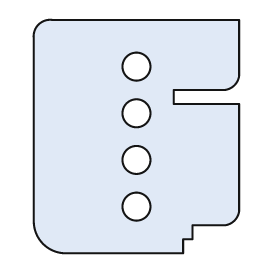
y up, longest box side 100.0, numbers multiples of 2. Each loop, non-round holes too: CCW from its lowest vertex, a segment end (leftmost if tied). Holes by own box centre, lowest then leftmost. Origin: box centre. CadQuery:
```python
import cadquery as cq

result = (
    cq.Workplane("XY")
    .moveTo(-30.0, -50.0)
    .lineTo(20.0, -50.0)
    .lineTo(20.0, -44.0)
    .lineTo(24.0, -44.0)
    .lineTo(24.0, -38.0)
    .lineTo(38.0, -38.0)
    .threePointArc((42.0, -36.0), (44.0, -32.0))
    .lineTo(44.0, 14.0)
    .lineTo(16.0, 14.0)
    .lineTo(16.0, 20.0)
    .lineTo(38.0, 20.0)
    .threePointArc((42.0, 22.0), (44.0, 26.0))
    .lineTo(44.0, 50.0)
    .lineTo(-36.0, 50.0)
    .threePointArc((-42.0, 48.0), (-44.0, 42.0))
    .lineTo(-44.0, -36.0)
    .threePointArc((-40.0, -46.0), (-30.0, -50.0))
    .close()
    .moveTo(0.0, -30.0)
    .circle(6.0)
    .moveTo(0.0, -10.0)
    .circle(6.0)
    .moveTo(0.0, 10.0)
    .circle(6.0)
    .moveTo(0.0, 30.0)
    .circle(6.0)
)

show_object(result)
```